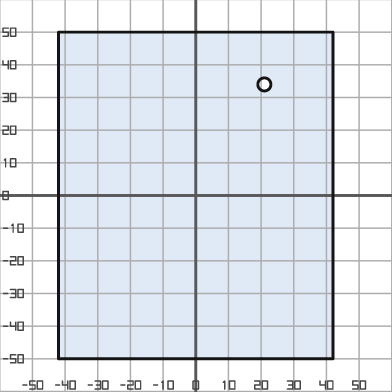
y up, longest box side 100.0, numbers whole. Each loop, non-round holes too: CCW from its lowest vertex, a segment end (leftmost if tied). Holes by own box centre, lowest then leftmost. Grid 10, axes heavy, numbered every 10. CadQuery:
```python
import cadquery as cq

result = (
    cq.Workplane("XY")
    .moveTo(-42.0, -50.0)
    .lineTo(42.0, -50.0)
    .lineTo(42.0, 50.0)
    .lineTo(-42.0, 50.0)
    .close()
    .moveTo(21.0, 34.0)
    .circle(2.0)
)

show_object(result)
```